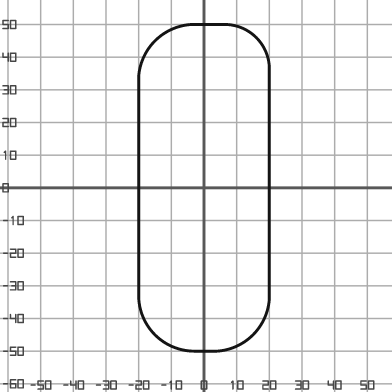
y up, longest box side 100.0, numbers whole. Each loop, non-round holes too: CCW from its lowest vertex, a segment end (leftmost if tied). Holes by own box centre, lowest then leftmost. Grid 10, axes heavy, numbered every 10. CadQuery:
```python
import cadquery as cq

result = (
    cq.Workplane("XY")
    .moveTo(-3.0, -50.0)
    .lineTo(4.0, -50.0)
    .threePointArc((15.0, -45.0), (20.0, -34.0))
    .lineTo(20.0, 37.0)
    .threePointArc((16.0, 46.0), (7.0, 50.0))
    .lineTo(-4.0, 50.0)
    .threePointArc((-15.0, 45.0), (-20.0, 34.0))
    .lineTo(-20.0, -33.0)
    .threePointArc((-15.0, -45.0), (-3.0, -50.0))
    .close()
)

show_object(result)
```